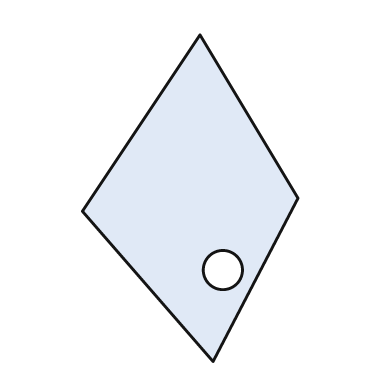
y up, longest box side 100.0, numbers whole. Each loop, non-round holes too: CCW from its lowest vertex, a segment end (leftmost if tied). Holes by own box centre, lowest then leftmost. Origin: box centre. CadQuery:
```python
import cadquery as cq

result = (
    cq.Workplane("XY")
    .moveTo(7.0, -50.0)
    .lineTo(33.0, 0.0)
    .lineTo(3.0, 50.0)
    .lineTo(-33.0, -4.0)
    .close()
    .moveTo(10.0, -22.0)
    .circle(6.0)
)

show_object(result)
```